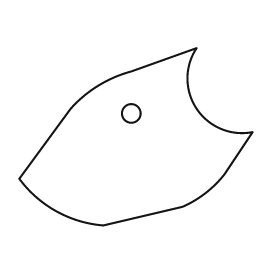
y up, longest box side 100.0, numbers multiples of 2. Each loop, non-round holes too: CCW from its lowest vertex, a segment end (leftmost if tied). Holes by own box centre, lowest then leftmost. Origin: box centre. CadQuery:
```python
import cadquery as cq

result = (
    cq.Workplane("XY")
    .moveTo(-14.0, -38.0)
    .lineTo(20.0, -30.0)
    .threePointArc((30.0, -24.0), (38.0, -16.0))
    .lineTo(50.0, 2.0)
    .threePointArc((26.0, 12.0), (26.0, 38.0))
    .lineTo(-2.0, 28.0)
    .threePointArc((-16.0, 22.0), (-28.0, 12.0))
    .lineTo(-50.0, -18.0)
    .threePointArc((-34.0, -32.0), (-14.0, -38.0))
    .close()
    .moveTo(-2.0, 10.0)
    .circle(4.0)
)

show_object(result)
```